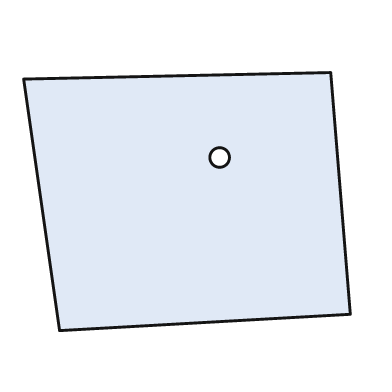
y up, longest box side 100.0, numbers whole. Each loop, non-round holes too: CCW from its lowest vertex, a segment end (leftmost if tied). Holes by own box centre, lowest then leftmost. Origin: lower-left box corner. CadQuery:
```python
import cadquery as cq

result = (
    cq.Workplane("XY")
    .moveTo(11.0, 0.0)
    .lineTo(100.0, 5.0)
    .lineTo(94.0, 79.0)
    .lineTo(0.0, 77.0)
    .close()
    .moveTo(60.0, 53.0)
    .circle(3.0)
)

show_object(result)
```